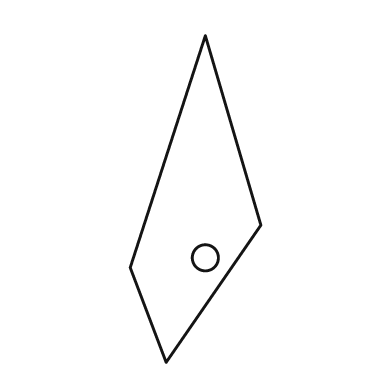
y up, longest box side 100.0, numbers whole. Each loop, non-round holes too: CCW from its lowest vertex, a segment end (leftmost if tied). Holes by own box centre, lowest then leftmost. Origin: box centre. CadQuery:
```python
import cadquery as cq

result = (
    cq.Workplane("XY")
    .moveTo(-9.0, -50.0)
    .lineTo(20.0, -8.0)
    .lineTo(3.0, 50.0)
    .lineTo(-20.0, -21.0)
    .close()
    .moveTo(3.0, -18.0)
    .circle(4.0)
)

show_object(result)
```